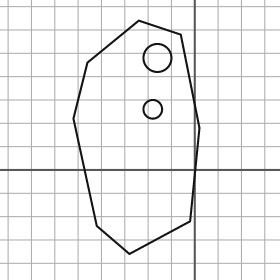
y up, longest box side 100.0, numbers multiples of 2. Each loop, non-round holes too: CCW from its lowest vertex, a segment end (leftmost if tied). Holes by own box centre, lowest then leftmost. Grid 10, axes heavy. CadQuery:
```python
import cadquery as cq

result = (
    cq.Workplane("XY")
    .moveTo(-28.0, -36.0)
    .lineTo(-2.0, -22.0)
    .lineTo(2.0, 18.0)
    .lineTo(-6.0, 58.0)
    .lineTo(-24.0, 64.0)
    .lineTo(-46.0, 46.0)
    .lineTo(-52.0, 22.0)
    .lineTo(-42.0, -24.0)
    .close()
    .moveTo(-18.0, 26.0)
    .circle(4.0)
    .moveTo(-16.0, 48.0)
    .circle(6.0)
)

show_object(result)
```